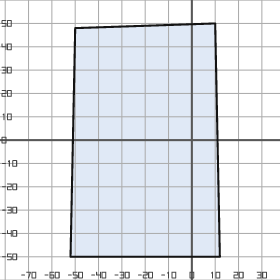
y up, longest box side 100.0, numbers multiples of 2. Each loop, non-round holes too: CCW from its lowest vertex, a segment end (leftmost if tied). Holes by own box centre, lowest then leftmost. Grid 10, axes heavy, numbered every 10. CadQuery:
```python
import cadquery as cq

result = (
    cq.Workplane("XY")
    .moveTo(-52.0, -50.0)
    .lineTo(12.0, -50.0)
    .lineTo(10.0, 50.0)
    .lineTo(-50.0, 48.0)
    .close()
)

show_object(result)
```